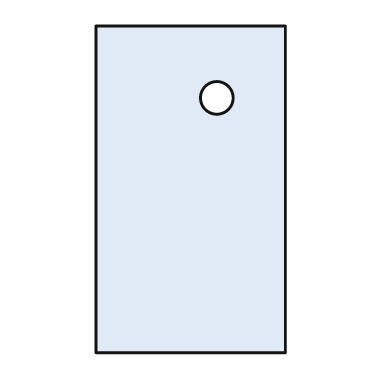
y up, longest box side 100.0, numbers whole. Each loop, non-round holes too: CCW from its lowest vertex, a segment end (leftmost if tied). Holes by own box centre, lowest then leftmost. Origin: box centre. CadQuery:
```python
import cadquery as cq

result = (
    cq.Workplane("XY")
    .moveTo(-29.0, -50.0)
    .lineTo(29.0, -50.0)
    .lineTo(29.0, 50.0)
    .lineTo(-29.0, 50.0)
    .close()
    .moveTo(8.0, 28.0)
    .circle(5.0)
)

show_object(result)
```